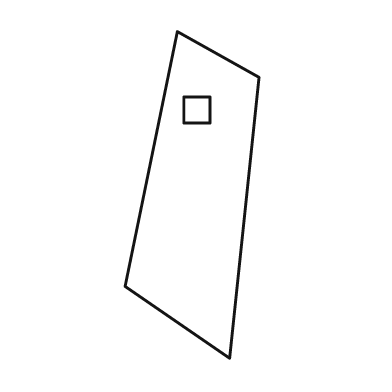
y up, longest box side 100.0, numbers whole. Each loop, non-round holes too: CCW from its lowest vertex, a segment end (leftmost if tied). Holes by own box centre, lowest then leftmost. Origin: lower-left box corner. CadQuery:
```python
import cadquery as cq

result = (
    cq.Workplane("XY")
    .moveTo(32.0, 0.0)
    .lineTo(41.0, 86.0)
    .lineTo(16.0, 100.0)
    .lineTo(0.0, 22.0)
    .close()
    .moveTo(18.0, 72.0)
    .lineTo(26.0, 72.0)
    .lineTo(26.0, 80.0)
    .lineTo(18.0, 80.0)
    .close()
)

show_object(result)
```